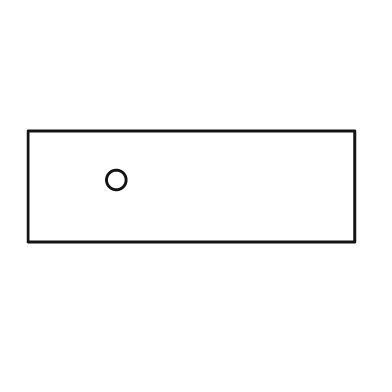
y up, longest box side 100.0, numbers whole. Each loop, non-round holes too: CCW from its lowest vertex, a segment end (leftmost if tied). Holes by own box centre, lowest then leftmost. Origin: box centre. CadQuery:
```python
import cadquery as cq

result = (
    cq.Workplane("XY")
    .moveTo(-50.0, -17.0)
    .lineTo(50.0, -17.0)
    .lineTo(50.0, 17.0)
    .lineTo(-50.0, 17.0)
    .close()
    .moveTo(-23.0, 2.0)
    .circle(3.0)
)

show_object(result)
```